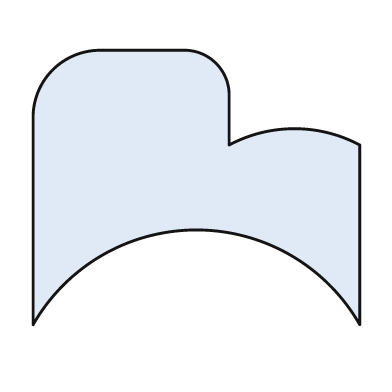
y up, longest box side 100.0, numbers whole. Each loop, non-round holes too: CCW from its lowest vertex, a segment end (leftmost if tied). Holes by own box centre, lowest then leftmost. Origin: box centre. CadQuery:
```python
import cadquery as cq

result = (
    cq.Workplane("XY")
    .moveTo(-50.0, -42.0)
    .threePointArc((0.0, -13.0), (50.0, -42.0))
    .lineTo(50.0, 13.0)
    .threePointArc((30.0, 18.0), (10.0, 13.0))
    .lineTo(10.0, 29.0)
    .threePointArc((6.0, 38.0), (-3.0, 42.0))
    .lineTo(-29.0, 42.0)
    .threePointArc((-44.0, 36.0), (-50.0, 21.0))
    .close()
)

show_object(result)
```